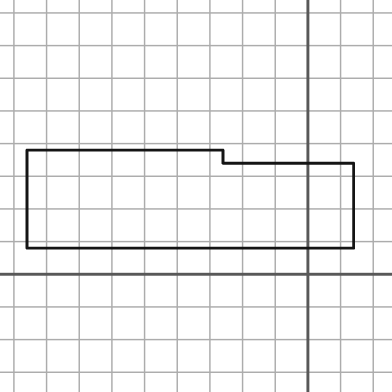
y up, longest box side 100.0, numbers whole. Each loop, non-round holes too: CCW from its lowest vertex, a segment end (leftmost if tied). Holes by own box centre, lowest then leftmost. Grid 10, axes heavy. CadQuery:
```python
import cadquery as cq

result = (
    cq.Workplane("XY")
    .moveTo(-86.0, 8.0)
    .lineTo(14.0, 8.0)
    .lineTo(14.0, 34.0)
    .lineTo(-26.0, 34.0)
    .lineTo(-26.0, 38.0)
    .lineTo(-86.0, 38.0)
    .close()
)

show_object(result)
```